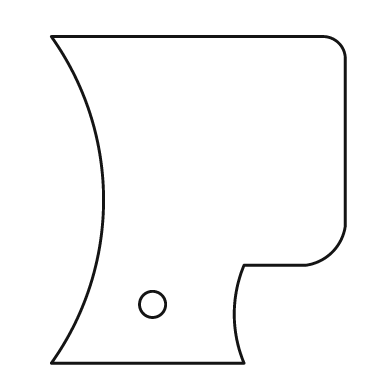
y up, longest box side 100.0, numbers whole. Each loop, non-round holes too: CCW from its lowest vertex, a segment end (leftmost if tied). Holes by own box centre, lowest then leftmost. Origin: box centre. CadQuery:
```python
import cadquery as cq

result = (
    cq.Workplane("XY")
    .moveTo(-45.0, -50.0)
    .lineTo(14.0, -50.0)
    .threePointArc((11.0, -35.0), (14.0, -20.0))
    .lineTo(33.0, -20.0)
    .threePointArc((41.0, -16.0), (45.0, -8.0))
    .lineTo(45.0, 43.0)
    .threePointArc((43.0, 48.0), (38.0, 50.0))
    .lineTo(-45.0, 50.0)
    .threePointArc((-29.0, 0.0), (-45.0, -50.0))
    .close()
    .moveTo(-14.0, -32.0)
    .circle(4.0)
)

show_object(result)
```